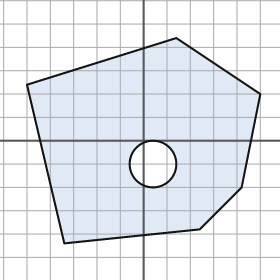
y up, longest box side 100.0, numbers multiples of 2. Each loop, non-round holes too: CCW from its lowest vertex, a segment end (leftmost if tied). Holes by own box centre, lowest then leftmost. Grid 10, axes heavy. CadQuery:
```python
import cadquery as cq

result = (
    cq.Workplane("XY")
    .moveTo(-34.0, -44.0)
    .lineTo(24.0, -38.0)
    .lineTo(42.0, -20.0)
    .lineTo(50.0, 20.0)
    .lineTo(14.0, 44.0)
    .lineTo(-50.0, 24.0)
    .close()
    .moveTo(4.0, -10.0)
    .circle(10.0)
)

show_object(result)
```